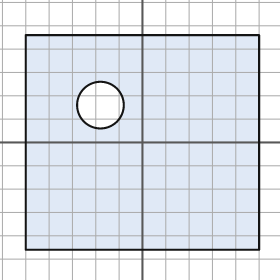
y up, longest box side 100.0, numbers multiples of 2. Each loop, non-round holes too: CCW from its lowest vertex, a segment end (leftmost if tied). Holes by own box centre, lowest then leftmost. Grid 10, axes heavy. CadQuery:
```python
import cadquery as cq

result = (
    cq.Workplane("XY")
    .moveTo(-50.0, -46.0)
    .lineTo(50.0, -46.0)
    .lineTo(50.0, 46.0)
    .lineTo(-50.0, 46.0)
    .close()
    .moveTo(-18.0, 16.0)
    .circle(10.0)
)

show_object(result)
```